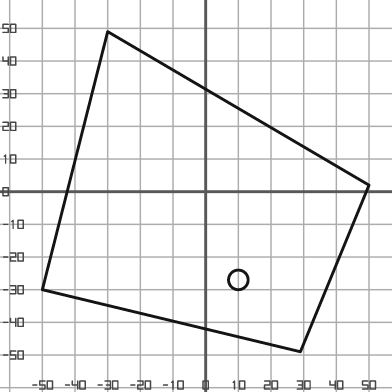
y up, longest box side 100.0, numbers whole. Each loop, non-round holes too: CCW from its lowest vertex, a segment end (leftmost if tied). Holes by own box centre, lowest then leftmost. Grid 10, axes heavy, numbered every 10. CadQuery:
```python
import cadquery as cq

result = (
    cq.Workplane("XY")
    .moveTo(29.0, -49.0)
    .lineTo(50.0, 2.0)
    .lineTo(-30.0, 49.0)
    .lineTo(-50.0, -30.0)
    .close()
    .moveTo(10.0, -27.0)
    .circle(3.0)
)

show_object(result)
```